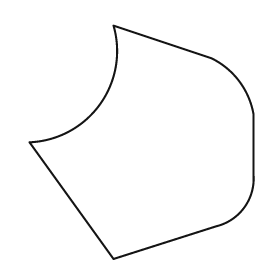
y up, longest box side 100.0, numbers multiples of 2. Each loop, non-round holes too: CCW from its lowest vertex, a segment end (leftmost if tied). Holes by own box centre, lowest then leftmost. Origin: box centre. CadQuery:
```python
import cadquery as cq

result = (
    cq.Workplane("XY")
    .moveTo(-12.0, -50.0)
    .lineTo(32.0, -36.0)
    .threePointArc((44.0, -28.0), (48.0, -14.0))
    .lineTo(48.0, 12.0)
    .threePointArc((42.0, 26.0), (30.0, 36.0))
    .lineTo(-12.0, 50.0)
    .threePointArc((-18.0, 16.0), (-48.0, 0.0))
    .close()
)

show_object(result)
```